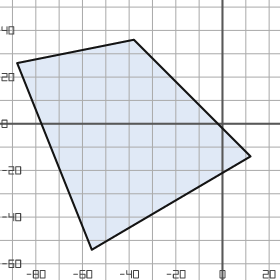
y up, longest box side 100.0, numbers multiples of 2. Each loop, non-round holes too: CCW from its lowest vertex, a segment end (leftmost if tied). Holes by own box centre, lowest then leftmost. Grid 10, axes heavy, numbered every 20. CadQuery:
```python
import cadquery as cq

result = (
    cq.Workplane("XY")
    .moveTo(-56.0, -54.0)
    .lineTo(12.0, -14.0)
    .lineTo(-38.0, 36.0)
    .lineTo(-88.0, 26.0)
    .close()
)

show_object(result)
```